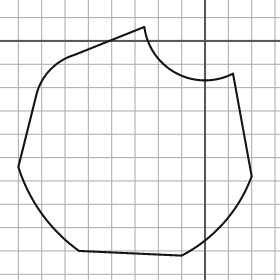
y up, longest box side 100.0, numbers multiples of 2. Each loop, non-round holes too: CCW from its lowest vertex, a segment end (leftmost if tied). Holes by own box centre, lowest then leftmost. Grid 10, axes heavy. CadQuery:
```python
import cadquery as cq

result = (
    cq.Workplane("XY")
    .moveTo(-10.0, -92.0)
    .threePointArc((8.0, -78.0), (20.0, -58.0))
    .lineTo(12.0, -14.0)
    .threePointArc((-12.0, -14.0), (-26.0, 6.0))
    .lineTo(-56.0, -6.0)
    .threePointArc((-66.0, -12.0), (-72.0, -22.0))
    .lineTo(-80.0, -54.0)
    .threePointArc((-70.0, -74.0), (-54.0, -90.0))
    .close()
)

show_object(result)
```